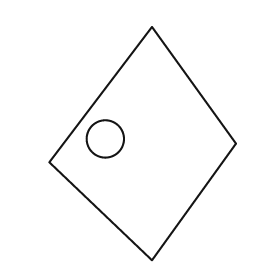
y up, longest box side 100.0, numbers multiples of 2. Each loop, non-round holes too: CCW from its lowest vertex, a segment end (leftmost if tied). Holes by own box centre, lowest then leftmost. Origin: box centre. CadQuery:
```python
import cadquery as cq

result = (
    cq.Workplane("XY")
    .moveTo(4.0, -50.0)
    .lineTo(40.0, 0.0)
    .lineTo(4.0, 50.0)
    .lineTo(-40.0, -8.0)
    .close()
    .moveTo(-16.0, 2.0)
    .circle(8.0)
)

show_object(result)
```